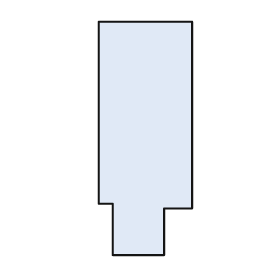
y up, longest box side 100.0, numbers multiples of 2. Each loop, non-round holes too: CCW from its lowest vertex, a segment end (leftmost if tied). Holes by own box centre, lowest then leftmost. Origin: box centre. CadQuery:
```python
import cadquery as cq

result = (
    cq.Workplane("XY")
    .moveTo(-14.0, -50.0)
    .lineTo(8.0, -50.0)
    .lineTo(8.0, -30.0)
    .lineTo(20.0, -30.0)
    .lineTo(20.0, 50.0)
    .lineTo(-20.0, 50.0)
    .lineTo(-20.0, -28.0)
    .lineTo(-14.0, -28.0)
    .close()
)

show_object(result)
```